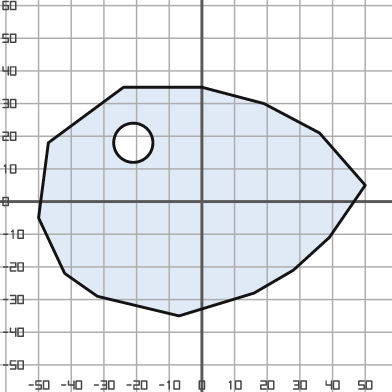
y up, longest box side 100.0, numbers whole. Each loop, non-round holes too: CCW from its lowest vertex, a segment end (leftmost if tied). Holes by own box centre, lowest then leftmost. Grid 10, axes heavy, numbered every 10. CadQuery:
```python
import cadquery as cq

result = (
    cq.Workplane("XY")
    .moveTo(-7.0, -35.0)
    .lineTo(16.0, -28.0)
    .lineTo(28.0, -21.0)
    .lineTo(39.0, -11.0)
    .lineTo(50.0, 5.0)
    .lineTo(36.0, 21.0)
    .lineTo(19.0, 30.0)
    .lineTo(0.0, 35.0)
    .lineTo(-24.0, 35.0)
    .lineTo(-47.0, 18.0)
    .lineTo(-50.0, -5.0)
    .lineTo(-42.0, -22.0)
    .lineTo(-32.0, -29.0)
    .close()
    .moveTo(-21.0, 18.0)
    .circle(6.0)
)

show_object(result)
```